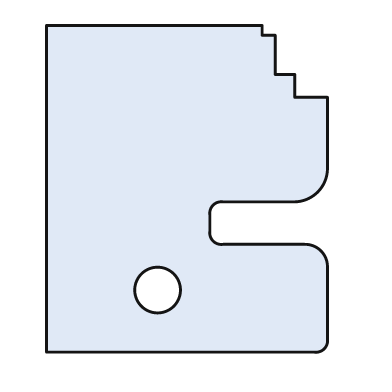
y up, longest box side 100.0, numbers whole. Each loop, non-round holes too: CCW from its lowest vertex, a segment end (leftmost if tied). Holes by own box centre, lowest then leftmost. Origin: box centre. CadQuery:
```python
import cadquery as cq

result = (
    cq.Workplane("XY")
    .moveTo(-43.0, -50.0)
    .lineTo(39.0, -50.0)
    .threePointArc((42.0, -49.0), (43.0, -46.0))
    .lineTo(43.0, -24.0)
    .threePointArc((41.0, -19.0), (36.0, -17.0))
    .lineTo(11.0, -17.0)
    .threePointArc((8.0, -16.0), (7.0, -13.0))
    .lineTo(7.0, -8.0)
    .threePointArc((8.0, -5.0), (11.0, -4.0))
    .lineTo(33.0, -4.0)
    .threePointArc((40.0, -1.0), (43.0, 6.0))
    .lineTo(43.0, 28.0)
    .lineTo(33.0, 28.0)
    .lineTo(33.0, 35.0)
    .lineTo(27.0, 35.0)
    .lineTo(27.0, 47.0)
    .lineTo(23.0, 47.0)
    .lineTo(23.0, 50.0)
    .lineTo(-43.0, 50.0)
    .close()
    .moveTo(-9.0, -31.0)
    .circle(7.0)
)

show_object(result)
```